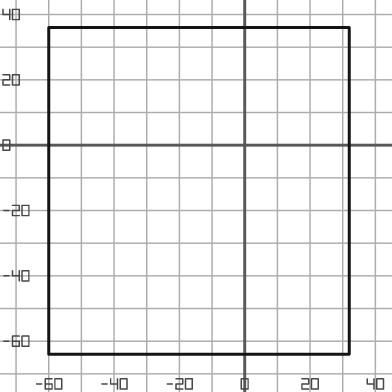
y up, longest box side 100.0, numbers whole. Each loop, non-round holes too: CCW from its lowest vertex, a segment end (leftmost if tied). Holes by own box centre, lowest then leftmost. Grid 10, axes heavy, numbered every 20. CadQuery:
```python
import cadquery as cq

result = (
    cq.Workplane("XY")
    .moveTo(-60.0, -64.0)
    .lineTo(32.0, -64.0)
    .lineTo(32.0, 36.0)
    .lineTo(-60.0, 36.0)
    .close()
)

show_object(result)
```